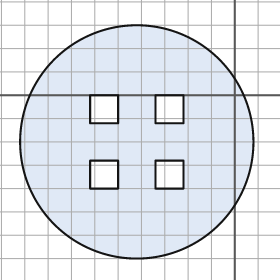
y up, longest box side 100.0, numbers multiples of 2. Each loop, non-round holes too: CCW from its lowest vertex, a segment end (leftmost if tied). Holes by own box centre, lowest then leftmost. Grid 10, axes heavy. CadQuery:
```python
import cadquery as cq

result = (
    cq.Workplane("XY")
    .moveTo(-42.0, -20.0)
    .circle(50.0)
    .moveTo(-62.0, -40.0)
    .lineTo(-50.0, -40.0)
    .lineTo(-50.0, -28.0)
    .lineTo(-62.0, -28.0)
    .close()
    .moveTo(-34.0, -40.0)
    .lineTo(-22.0, -40.0)
    .lineTo(-22.0, -28.0)
    .lineTo(-34.0, -28.0)
    .close()
    .moveTo(-62.0, -12.0)
    .lineTo(-50.0, -12.0)
    .lineTo(-50.0, 0.0)
    .lineTo(-62.0, 0.0)
    .close()
    .moveTo(-34.0, -12.0)
    .lineTo(-22.0, -12.0)
    .lineTo(-22.0, 0.0)
    .lineTo(-34.0, 0.0)
    .close()
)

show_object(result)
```